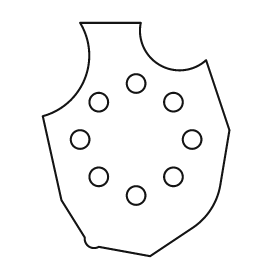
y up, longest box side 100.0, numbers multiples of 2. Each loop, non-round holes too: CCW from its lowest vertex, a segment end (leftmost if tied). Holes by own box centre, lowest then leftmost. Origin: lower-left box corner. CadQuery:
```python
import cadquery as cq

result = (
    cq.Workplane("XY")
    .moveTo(46.0, 0.0)
    .lineTo(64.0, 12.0)
    .threePointArc((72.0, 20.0), (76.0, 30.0))
    .lineTo(80.0, 54.0)
    .lineTo(70.0, 84.0)
    .threePointArc((50.0, 82.0), (42.0, 100.0))
    .lineTo(16.0, 100.0)
    .threePointArc((18.0, 76.0), (0.0, 60.0))
    .lineTo(8.0, 24.0)
    .lineTo(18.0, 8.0)
    .threePointArc((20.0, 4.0), (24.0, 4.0))
    .close()
    .moveTo(40.0, 26.0)
    .circle(4.0)
    .moveTo(24.0, 34.0)
    .circle(4.0)
    .moveTo(56.0, 34.0)
    .circle(4.0)
    .moveTo(16.0, 50.0)
    .circle(4.0)
    .moveTo(64.0, 50.0)
    .circle(4.0)
    .moveTo(24.0, 66.0)
    .circle(4.0)
    .moveTo(56.0, 66.0)
    .circle(4.0)
    .moveTo(40.0, 74.0)
    .circle(4.0)
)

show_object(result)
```